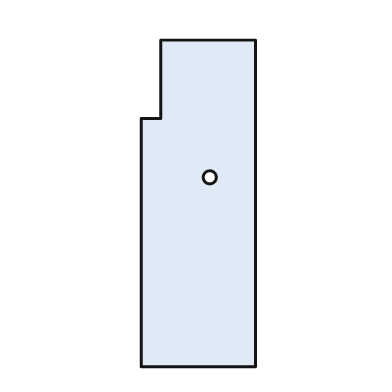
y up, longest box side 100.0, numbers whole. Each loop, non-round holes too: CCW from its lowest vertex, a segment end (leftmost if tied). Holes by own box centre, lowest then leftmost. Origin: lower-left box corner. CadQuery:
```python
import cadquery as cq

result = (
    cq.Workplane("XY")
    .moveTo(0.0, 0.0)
    .lineTo(35.0, 0.0)
    .lineTo(35.0, 100.0)
    .lineTo(6.0, 100.0)
    .lineTo(6.0, 76.0)
    .lineTo(0.0, 76.0)
    .close()
    .moveTo(21.0, 58.0)
    .circle(2.0)
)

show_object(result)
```